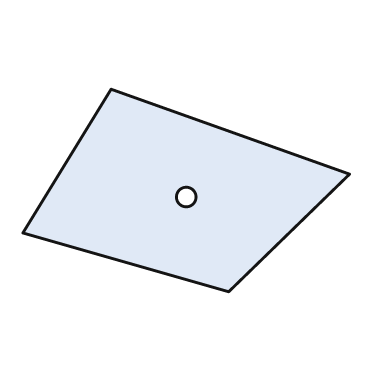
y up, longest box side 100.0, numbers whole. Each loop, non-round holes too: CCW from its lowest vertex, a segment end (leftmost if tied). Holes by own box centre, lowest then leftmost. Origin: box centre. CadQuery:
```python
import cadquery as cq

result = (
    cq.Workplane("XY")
    .moveTo(13.0, -31.0)
    .lineTo(50.0, 5.0)
    .lineTo(-23.0, 31.0)
    .lineTo(-50.0, -13.0)
    .close()
    .moveTo(0.0, -2.0)
    .circle(3.0)
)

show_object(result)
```